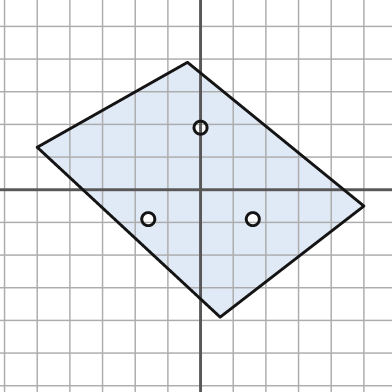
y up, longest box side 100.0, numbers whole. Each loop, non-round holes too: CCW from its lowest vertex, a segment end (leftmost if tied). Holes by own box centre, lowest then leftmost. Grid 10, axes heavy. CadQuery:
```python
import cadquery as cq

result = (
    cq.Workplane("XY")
    .moveTo(6.0, -39.0)
    .lineTo(50.0, -5.0)
    .lineTo(-4.0, 39.0)
    .lineTo(-50.0, 13.0)
    .close()
    .moveTo(-16.0, -9.0)
    .circle(2.0)
    .moveTo(16.0, -9.0)
    .circle(2.0)
    .moveTo(0.0, 19.0)
    .circle(2.0)
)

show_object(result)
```